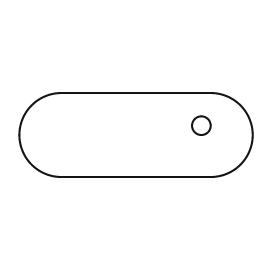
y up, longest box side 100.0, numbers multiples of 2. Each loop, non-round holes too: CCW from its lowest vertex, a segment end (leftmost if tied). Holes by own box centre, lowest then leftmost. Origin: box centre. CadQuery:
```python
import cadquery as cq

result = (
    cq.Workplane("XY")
    .moveTo(-32.0, -18.0)
    .lineTo(32.0, -18.0)
    .threePointArc((50.0, 0.0), (32.0, 18.0))
    .lineTo(-32.0, 18.0)
    .threePointArc((-50.0, 0.0), (-32.0, -18.0))
    .close()
    .moveTo(28.0, 4.0)
    .circle(4.0)
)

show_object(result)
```